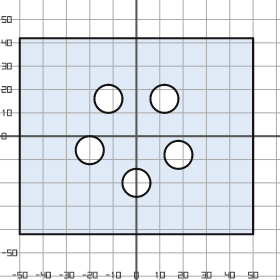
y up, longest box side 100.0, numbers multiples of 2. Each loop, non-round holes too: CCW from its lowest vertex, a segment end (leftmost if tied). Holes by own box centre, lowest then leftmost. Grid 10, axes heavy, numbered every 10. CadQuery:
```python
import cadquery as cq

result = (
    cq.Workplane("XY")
    .moveTo(-50.0, -42.0)
    .lineTo(50.0, -42.0)
    .lineTo(50.0, 42.0)
    .lineTo(-50.0, 42.0)
    .close()
    .moveTo(0.0, -20.0)
    .circle(6.0)
    .moveTo(18.0, -8.0)
    .circle(6.0)
    .moveTo(-20.0, -6.0)
    .circle(6.0)
    .moveTo(-12.0, 16.0)
    .circle(6.0)
    .moveTo(12.0, 16.0)
    .circle(6.0)
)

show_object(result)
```